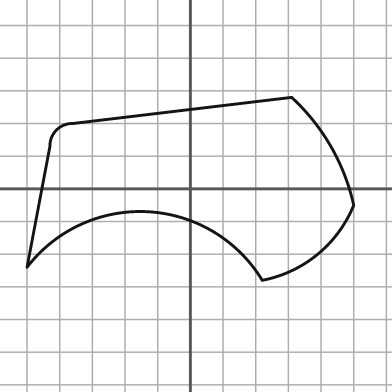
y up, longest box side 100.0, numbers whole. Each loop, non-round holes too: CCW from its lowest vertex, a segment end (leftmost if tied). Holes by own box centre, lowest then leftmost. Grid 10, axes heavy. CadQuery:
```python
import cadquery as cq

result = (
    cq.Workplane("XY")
    .moveTo(22.0, -28.0)
    .threePointArc((39.0, -20.0), (50.0, -5.0))
    .threePointArc((43.0, 13.0), (31.0, 28.0))
    .lineTo(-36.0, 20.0)
    .threePointArc((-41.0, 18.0), (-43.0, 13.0))
    .lineTo(-50.0, -24.0)
    .threePointArc((-13.0, -7.0), (22.0, -28.0))
    .close()
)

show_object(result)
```